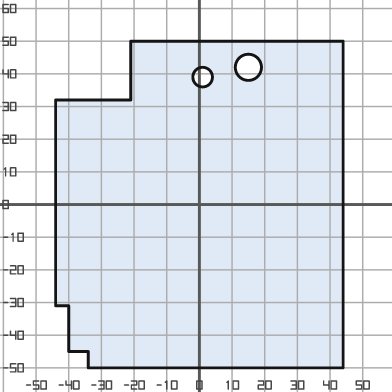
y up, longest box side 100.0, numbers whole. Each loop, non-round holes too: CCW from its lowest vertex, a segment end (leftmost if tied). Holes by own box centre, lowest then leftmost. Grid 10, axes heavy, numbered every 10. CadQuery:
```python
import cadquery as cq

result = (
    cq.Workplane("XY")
    .moveTo(-34.0, -50.0)
    .lineTo(44.0, -50.0)
    .lineTo(44.0, 50.0)
    .lineTo(-21.0, 50.0)
    .lineTo(-21.0, 32.0)
    .lineTo(-44.0, 32.0)
    .lineTo(-44.0, -31.0)
    .lineTo(-40.0, -31.0)
    .lineTo(-40.0, -45.0)
    .lineTo(-34.0, -45.0)
    .close()
    .moveTo(1.0, 39.0)
    .circle(3.0)
    .moveTo(15.0, 42.0)
    .circle(4.0)
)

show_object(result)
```